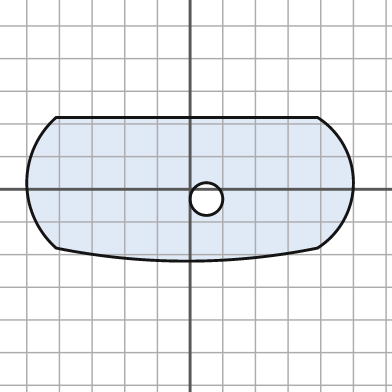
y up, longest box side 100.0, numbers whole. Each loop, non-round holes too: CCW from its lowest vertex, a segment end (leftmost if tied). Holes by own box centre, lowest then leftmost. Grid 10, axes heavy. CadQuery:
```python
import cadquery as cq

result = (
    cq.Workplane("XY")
    .moveTo(-41.0, -18.0)
    .threePointArc((-1.0, -22.0), (39.0, -18.0))
    .threePointArc((50.0, 2.0), (39.0, 22.0))
    .lineTo(-41.0, 22.0)
    .threePointArc((-50.0, 2.0), (-41.0, -18.0))
    .close()
    .moveTo(5.0, -3.0)
    .circle(5.0)
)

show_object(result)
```